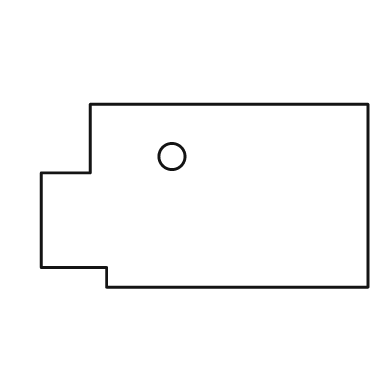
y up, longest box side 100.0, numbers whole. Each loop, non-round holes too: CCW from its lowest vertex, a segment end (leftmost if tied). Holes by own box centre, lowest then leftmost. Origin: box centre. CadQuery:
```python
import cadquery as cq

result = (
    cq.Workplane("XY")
    .moveTo(-30.0, -28.0)
    .lineTo(50.0, -28.0)
    .lineTo(50.0, 28.0)
    .lineTo(-35.0, 28.0)
    .lineTo(-35.0, 7.0)
    .lineTo(-50.0, 7.0)
    .lineTo(-50.0, -22.0)
    .lineTo(-30.0, -22.0)
    .close()
    .moveTo(-10.0, 12.0)
    .circle(4.0)
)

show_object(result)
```